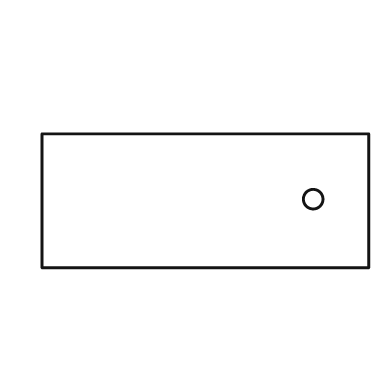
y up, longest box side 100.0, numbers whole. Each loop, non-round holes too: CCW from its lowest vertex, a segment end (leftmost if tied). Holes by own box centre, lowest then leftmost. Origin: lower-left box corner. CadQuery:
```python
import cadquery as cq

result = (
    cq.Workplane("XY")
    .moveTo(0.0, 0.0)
    .lineTo(100.0, 0.0)
    .lineTo(100.0, 41.0)
    .lineTo(0.0, 41.0)
    .close()
    .moveTo(83.0, 21.0)
    .circle(3.0)
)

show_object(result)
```